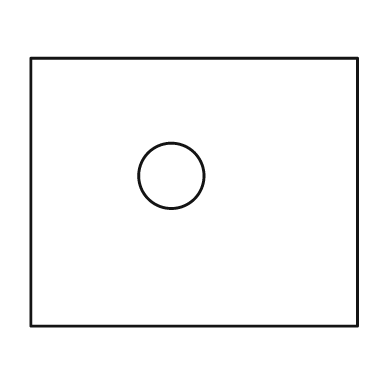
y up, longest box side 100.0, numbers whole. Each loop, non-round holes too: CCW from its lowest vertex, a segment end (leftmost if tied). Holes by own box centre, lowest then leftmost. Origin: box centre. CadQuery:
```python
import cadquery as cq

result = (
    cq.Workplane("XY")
    .moveTo(-50.0, -41.0)
    .lineTo(50.0, -41.0)
    .lineTo(50.0, 41.0)
    .lineTo(-50.0, 41.0)
    .close()
    .moveTo(-7.0, 5.0)
    .circle(10.0)
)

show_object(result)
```